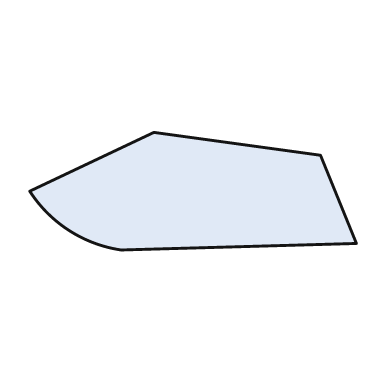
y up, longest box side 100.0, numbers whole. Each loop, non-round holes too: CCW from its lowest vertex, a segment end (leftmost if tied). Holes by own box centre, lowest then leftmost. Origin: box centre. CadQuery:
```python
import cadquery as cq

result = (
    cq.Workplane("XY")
    .moveTo(-22.0, -18.0)
    .lineTo(50.0, -16.0)
    .lineTo(39.0, 11.0)
    .lineTo(-12.0, 18.0)
    .lineTo(-50.0, 0.0)
    .threePointArc((-38.0, -12.0), (-22.0, -18.0))
    .close()
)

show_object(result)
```